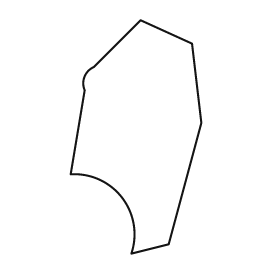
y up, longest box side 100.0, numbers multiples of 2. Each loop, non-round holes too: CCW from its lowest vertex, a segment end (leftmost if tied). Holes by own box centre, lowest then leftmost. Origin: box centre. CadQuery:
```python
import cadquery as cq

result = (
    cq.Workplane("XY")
    .moveTo(-2.0, -50.0)
    .lineTo(14.0, -46.0)
    .lineTo(28.0, 6.0)
    .lineTo(24.0, 40.0)
    .lineTo(2.0, 50.0)
    .lineTo(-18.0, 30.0)
    .threePointArc((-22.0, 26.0), (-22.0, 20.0))
    .lineTo(-28.0, -16.0)
    .threePointArc((-6.0, -26.0), (-2.0, -50.0))
    .close()
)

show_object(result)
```